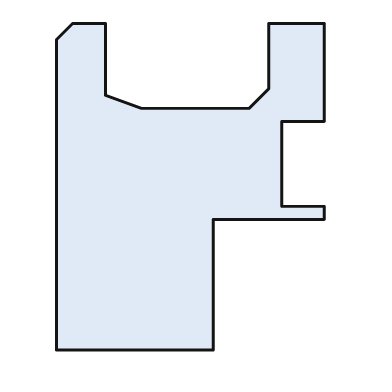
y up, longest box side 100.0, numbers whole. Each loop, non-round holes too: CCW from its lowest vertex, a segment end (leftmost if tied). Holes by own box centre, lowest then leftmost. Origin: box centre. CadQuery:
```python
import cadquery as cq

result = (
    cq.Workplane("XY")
    .moveTo(-41.0, -50.0)
    .lineTo(7.0, -50.0)
    .lineTo(7.0, -10.0)
    .lineTo(41.0, -10.0)
    .lineTo(41.0, -6.0)
    .lineTo(28.0, -6.0)
    .lineTo(28.0, 20.0)
    .lineTo(41.0, 20.0)
    .lineTo(41.0, 50.0)
    .lineTo(24.0, 50.0)
    .lineTo(24.0, 30.0)
    .lineTo(18.0, 24.0)
    .lineTo(-15.0, 24.0)
    .lineTo(-26.0, 28.0)
    .lineTo(-26.0, 50.0)
    .lineTo(-36.0, 50.0)
    .lineTo(-41.0, 45.0)
    .close()
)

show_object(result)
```